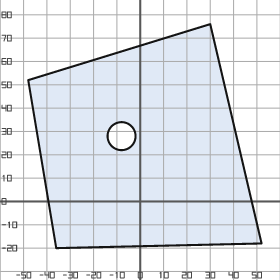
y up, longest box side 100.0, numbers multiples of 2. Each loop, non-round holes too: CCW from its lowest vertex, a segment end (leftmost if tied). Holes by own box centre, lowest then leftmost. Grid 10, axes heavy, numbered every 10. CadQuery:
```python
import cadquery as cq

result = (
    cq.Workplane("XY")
    .moveTo(-36.0, -20.0)
    .lineTo(52.0, -18.0)
    .lineTo(30.0, 76.0)
    .lineTo(-48.0, 52.0)
    .close()
    .moveTo(-8.0, 28.0)
    .circle(6.0)
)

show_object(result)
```